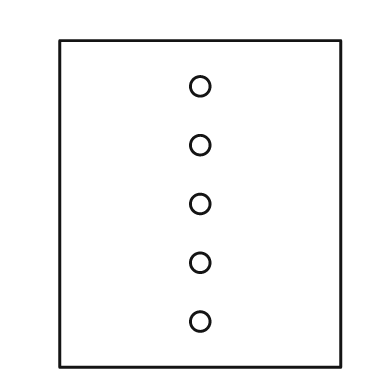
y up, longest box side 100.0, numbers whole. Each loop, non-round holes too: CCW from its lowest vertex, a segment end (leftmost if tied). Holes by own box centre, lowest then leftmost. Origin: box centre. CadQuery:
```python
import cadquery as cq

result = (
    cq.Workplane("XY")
    .moveTo(-43.0, -50.0)
    .lineTo(43.0, -50.0)
    .lineTo(43.0, 50.0)
    .lineTo(-43.0, 50.0)
    .close()
    .moveTo(0.0, -36.0)
    .circle(3.0)
    .moveTo(0.0, -18.0)
    .circle(3.0)
    .moveTo(0.0, 0.0)
    .circle(3.0)
    .moveTo(0.0, 18.0)
    .circle(3.0)
    .moveTo(0.0, 36.0)
    .circle(3.0)
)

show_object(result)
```